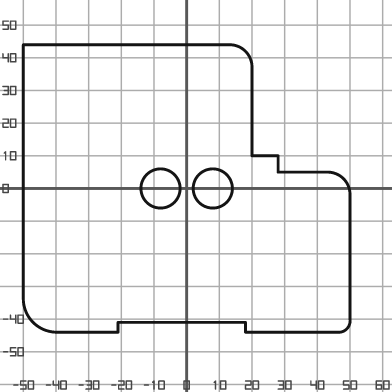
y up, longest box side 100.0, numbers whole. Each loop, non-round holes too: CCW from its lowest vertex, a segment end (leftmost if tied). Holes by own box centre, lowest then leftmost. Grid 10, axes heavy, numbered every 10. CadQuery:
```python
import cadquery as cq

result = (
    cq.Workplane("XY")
    .moveTo(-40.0, -44.0)
    .lineTo(-21.0, -44.0)
    .lineTo(-21.0, -41.0)
    .lineTo(18.0, -41.0)
    .lineTo(18.0, -44.0)
    .lineTo(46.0, -44.0)
    .threePointArc((49.0, -43.0), (50.0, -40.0))
    .lineTo(50.0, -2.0)
    .threePointArc((48.0, 3.0), (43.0, 5.0))
    .lineTo(28.0, 5.0)
    .lineTo(28.0, 10.0)
    .lineTo(20.0, 10.0)
    .lineTo(20.0, 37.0)
    .threePointArc((18.0, 42.0), (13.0, 44.0))
    .lineTo(-50.0, 44.0)
    .lineTo(-50.0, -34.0)
    .threePointArc((-47.0, -41.0), (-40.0, -44.0))
    .close()
    .moveTo(-8.0, 0.0)
    .circle(6.0)
    .moveTo(8.0, 0.0)
    .circle(6.0)
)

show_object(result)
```